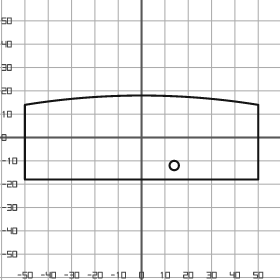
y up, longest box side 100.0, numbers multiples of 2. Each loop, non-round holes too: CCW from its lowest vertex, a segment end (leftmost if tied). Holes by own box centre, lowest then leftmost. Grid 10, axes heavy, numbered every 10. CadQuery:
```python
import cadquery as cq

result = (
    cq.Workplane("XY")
    .moveTo(-50.0, -18.0)
    .lineTo(50.0, -18.0)
    .lineTo(50.0, 14.0)
    .threePointArc((0.0, 18.0), (-50.0, 14.0))
    .close()
    .moveTo(14.0, -12.0)
    .circle(2.0)
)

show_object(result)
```